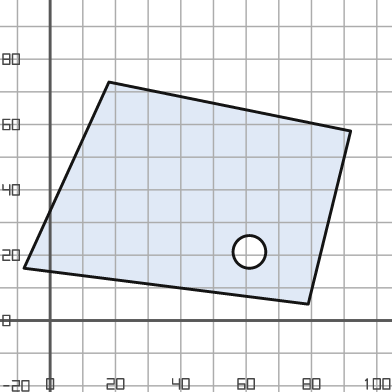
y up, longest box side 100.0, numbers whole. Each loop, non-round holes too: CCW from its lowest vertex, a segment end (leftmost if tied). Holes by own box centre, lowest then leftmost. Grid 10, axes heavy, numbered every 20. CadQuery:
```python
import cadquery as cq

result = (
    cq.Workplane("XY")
    .moveTo(79.0, 5.0)
    .lineTo(92.0, 58.0)
    .lineTo(18.0, 73.0)
    .lineTo(-8.0, 16.0)
    .close()
    .moveTo(61.0, 21.0)
    .circle(5.0)
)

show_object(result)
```